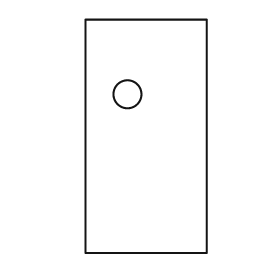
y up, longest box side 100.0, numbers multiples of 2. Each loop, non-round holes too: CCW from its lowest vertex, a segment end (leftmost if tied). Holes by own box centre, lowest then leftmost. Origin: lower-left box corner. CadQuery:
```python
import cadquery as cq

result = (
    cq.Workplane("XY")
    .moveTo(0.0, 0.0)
    .lineTo(52.0, 0.0)
    .lineTo(52.0, 100.0)
    .lineTo(0.0, 100.0)
    .close()
    .moveTo(18.0, 68.0)
    .circle(6.0)
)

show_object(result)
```